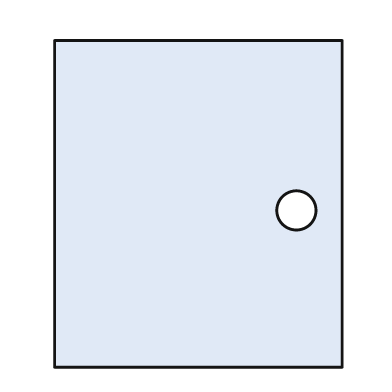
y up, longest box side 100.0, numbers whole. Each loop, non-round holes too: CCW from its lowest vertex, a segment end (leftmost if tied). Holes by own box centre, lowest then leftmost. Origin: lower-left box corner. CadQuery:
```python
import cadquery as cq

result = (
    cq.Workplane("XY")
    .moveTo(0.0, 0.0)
    .lineTo(88.0, 0.0)
    .lineTo(88.0, 100.0)
    .lineTo(0.0, 100.0)
    .close()
    .moveTo(74.0, 48.0)
    .circle(6.0)
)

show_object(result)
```